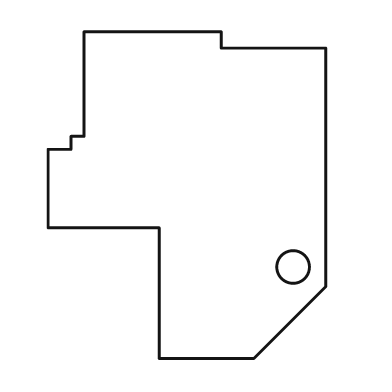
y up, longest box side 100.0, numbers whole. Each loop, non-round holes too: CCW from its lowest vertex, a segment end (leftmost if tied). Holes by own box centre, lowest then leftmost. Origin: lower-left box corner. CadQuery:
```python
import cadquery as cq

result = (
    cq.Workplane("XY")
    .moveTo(34.0, 0.0)
    .lineTo(63.0, 0.0)
    .lineTo(85.0, 22.0)
    .lineTo(85.0, 95.0)
    .lineTo(53.0, 95.0)
    .lineTo(53.0, 100.0)
    .lineTo(11.0, 100.0)
    .lineTo(11.0, 68.0)
    .lineTo(7.0, 68.0)
    .lineTo(7.0, 64.0)
    .lineTo(0.0, 64.0)
    .lineTo(0.0, 40.0)
    .lineTo(34.0, 40.0)
    .close()
    .moveTo(75.0, 28.0)
    .circle(5.0)
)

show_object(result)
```